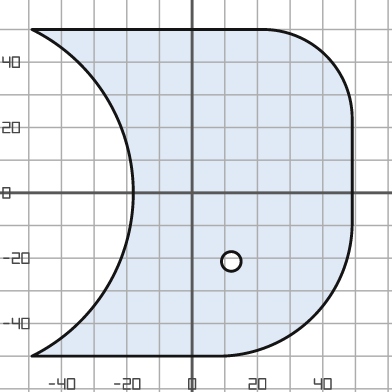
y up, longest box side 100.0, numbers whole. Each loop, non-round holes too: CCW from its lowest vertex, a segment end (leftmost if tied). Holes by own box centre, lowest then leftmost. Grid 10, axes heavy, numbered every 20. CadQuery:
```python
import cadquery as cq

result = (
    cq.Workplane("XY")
    .moveTo(-49.0, -50.0)
    .lineTo(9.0, -50.0)
    .threePointArc((37.0, -38.0), (49.0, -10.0))
    .lineTo(49.0, 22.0)
    .threePointArc((41.0, 42.0), (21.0, 50.0))
    .lineTo(-49.0, 50.0)
    .threePointArc((-18.0, 0.0), (-49.0, -50.0))
    .close()
    .moveTo(12.0, -21.0)
    .circle(3.0)
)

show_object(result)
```